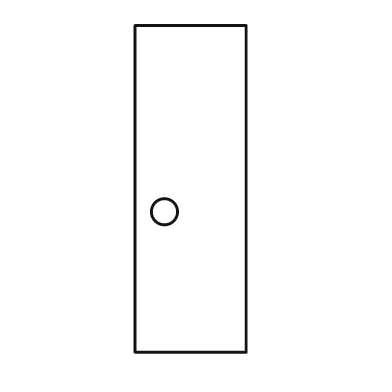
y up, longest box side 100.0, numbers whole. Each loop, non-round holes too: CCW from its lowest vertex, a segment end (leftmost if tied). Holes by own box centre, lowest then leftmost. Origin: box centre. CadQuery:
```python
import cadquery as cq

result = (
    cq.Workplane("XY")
    .moveTo(-17.0, -50.0)
    .lineTo(17.0, -50.0)
    .lineTo(17.0, 50.0)
    .lineTo(-17.0, 50.0)
    .close()
    .moveTo(-8.0, -7.0)
    .circle(4.0)
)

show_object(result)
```